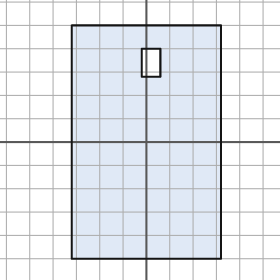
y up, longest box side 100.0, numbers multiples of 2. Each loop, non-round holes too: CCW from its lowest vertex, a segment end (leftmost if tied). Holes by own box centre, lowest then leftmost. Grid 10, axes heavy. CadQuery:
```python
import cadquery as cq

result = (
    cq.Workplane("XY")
    .moveTo(-32.0, -50.0)
    .lineTo(32.0, -50.0)
    .lineTo(32.0, 50.0)
    .lineTo(-32.0, 50.0)
    .close()
    .moveTo(-2.0, 28.0)
    .lineTo(6.0, 28.0)
    .lineTo(6.0, 40.0)
    .lineTo(-2.0, 40.0)
    .close()
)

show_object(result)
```